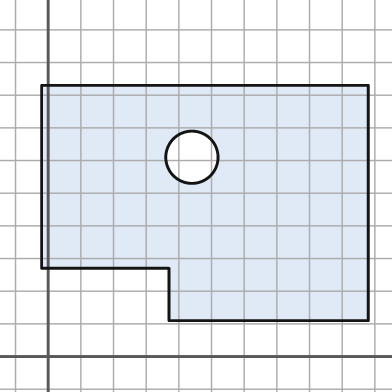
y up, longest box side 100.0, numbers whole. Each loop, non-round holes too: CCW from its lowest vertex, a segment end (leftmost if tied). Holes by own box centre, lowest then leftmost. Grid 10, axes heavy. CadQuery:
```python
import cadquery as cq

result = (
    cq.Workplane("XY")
    .moveTo(37.0, 11.0)
    .lineTo(98.0, 11.0)
    .lineTo(98.0, 83.0)
    .lineTo(-2.0, 83.0)
    .lineTo(-2.0, 27.0)
    .lineTo(37.0, 27.0)
    .close()
    .moveTo(44.0, 61.0)
    .circle(8.0)
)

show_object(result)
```